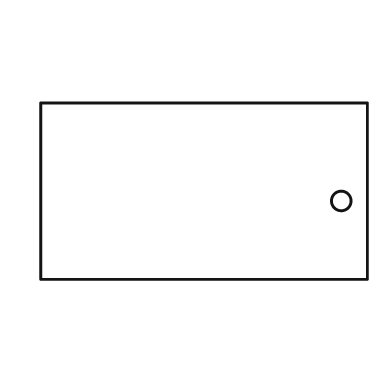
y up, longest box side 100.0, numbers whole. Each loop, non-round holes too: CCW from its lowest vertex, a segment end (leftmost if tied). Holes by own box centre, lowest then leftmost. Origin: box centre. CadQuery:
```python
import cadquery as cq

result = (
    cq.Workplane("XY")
    .moveTo(-50.0, -27.0)
    .lineTo(50.0, -27.0)
    .lineTo(50.0, 27.0)
    .lineTo(-50.0, 27.0)
    .close()
    .moveTo(42.0, -3.0)
    .circle(3.0)
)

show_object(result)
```